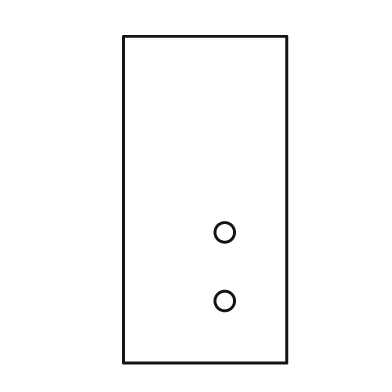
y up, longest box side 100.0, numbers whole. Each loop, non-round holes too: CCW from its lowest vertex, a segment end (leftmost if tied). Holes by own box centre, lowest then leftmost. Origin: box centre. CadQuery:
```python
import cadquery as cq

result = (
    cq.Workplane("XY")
    .moveTo(-25.0, -50.0)
    .lineTo(25.0, -50.0)
    .lineTo(25.0, 50.0)
    .lineTo(-25.0, 50.0)
    .close()
    .moveTo(6.0, -31.0)
    .circle(3.0)
    .moveTo(6.0, -10.0)
    .circle(3.0)
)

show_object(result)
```